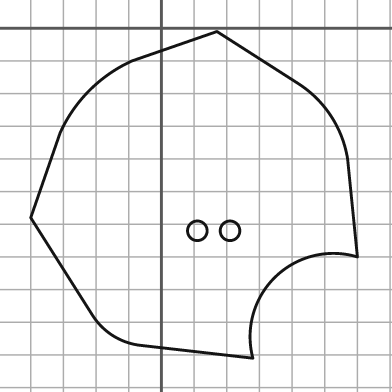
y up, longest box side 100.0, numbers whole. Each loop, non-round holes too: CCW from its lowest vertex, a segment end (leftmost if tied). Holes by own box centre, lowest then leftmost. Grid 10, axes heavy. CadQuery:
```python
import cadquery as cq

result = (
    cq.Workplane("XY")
    .moveTo(28.0, -101.0)
    .threePointArc((35.0, -76.0), (60.0, -70.0))
    .lineTo(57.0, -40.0)
    .threePointArc((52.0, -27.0), (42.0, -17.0))
    .lineTo(17.0, -1.0)
    .lineTo(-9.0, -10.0)
    .threePointArc((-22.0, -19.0), (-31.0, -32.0))
    .lineTo(-40.0, -58.0)
    .lineTo(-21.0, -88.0)
    .threePointArc((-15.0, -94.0), (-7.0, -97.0))
    .close()
    .moveTo(11.0, -62.0)
    .circle(3.0)
    .moveTo(21.0, -62.0)
    .circle(3.0)
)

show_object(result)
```